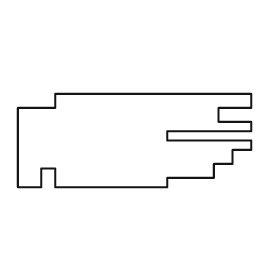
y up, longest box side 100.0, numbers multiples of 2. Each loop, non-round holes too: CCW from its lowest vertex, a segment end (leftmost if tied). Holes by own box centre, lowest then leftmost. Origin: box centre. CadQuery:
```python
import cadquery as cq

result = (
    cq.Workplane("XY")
    .moveTo(-50.0, -20.0)
    .lineTo(-40.0, -20.0)
    .lineTo(-40.0, -12.0)
    .lineTo(-34.0, -12.0)
    .lineTo(-34.0, -20.0)
    .lineTo(14.0, -20.0)
    .lineTo(14.0, -16.0)
    .lineTo(34.0, -16.0)
    .lineTo(34.0, -10.0)
    .lineTo(42.0, -10.0)
    .lineTo(42.0, -4.0)
    .lineTo(50.0, -4.0)
    .lineTo(50.0, 0.0)
    .lineTo(14.0, 0.0)
    .lineTo(14.0, 4.0)
    .lineTo(50.0, 4.0)
    .lineTo(50.0, 8.0)
    .lineTo(36.0, 8.0)
    .lineTo(36.0, 14.0)
    .lineTo(50.0, 14.0)
    .lineTo(50.0, 20.0)
    .lineTo(-34.0, 20.0)
    .lineTo(-34.0, 14.0)
    .lineTo(-50.0, 14.0)
    .close()
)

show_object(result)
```